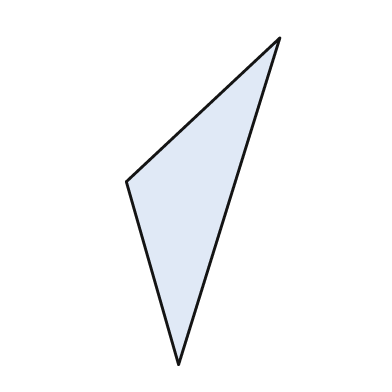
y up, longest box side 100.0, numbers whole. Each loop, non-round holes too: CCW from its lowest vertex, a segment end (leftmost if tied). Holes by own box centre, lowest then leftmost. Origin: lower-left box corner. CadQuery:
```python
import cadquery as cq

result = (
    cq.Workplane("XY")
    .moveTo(16.0, 0.0)
    .lineTo(47.0, 100.0)
    .lineTo(0.0, 56.0)
    .close()
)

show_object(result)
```